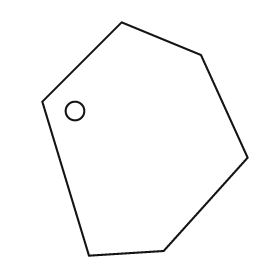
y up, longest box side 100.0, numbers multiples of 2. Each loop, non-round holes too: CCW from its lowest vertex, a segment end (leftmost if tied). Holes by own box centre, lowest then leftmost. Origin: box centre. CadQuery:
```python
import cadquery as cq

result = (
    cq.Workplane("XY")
    .moveTo(-24.0, -50.0)
    .lineTo(8.0, -48.0)
    .lineTo(44.0, -8.0)
    .lineTo(24.0, 36.0)
    .lineTo(-10.0, 50.0)
    .lineTo(-44.0, 16.0)
    .close()
    .moveTo(-30.0, 12.0)
    .circle(4.0)
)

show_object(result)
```